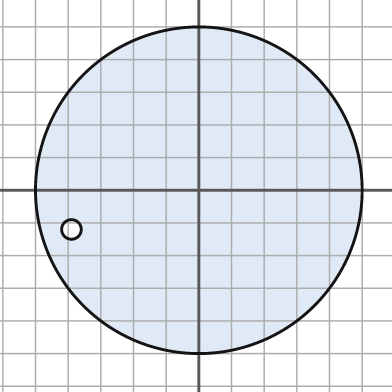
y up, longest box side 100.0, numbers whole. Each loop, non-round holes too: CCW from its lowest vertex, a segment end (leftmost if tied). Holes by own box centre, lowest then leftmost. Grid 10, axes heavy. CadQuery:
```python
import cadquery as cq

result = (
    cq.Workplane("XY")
    .moveTo(0.0, 0.0)
    .circle(50.0)
    .moveTo(-39.0, -12.0)
    .circle(3.0)
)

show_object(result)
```